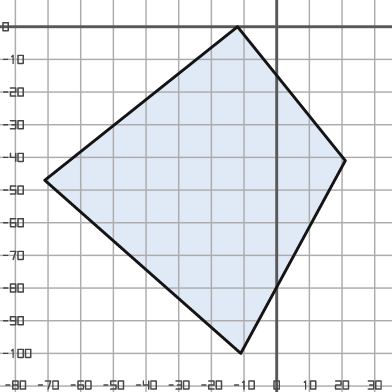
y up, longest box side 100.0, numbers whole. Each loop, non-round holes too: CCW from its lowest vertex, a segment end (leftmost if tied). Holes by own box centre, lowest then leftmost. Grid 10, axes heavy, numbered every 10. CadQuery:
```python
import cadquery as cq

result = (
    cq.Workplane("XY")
    .moveTo(-11.0, -100.0)
    .lineTo(21.0, -41.0)
    .lineTo(-12.0, 0.0)
    .lineTo(-71.0, -47.0)
    .close()
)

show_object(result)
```